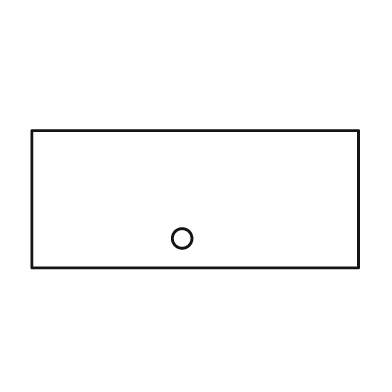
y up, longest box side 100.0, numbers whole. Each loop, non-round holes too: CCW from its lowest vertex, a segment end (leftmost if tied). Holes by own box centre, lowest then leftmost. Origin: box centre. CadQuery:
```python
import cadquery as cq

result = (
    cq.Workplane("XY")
    .moveTo(-50.0, -21.0)
    .lineTo(50.0, -21.0)
    .lineTo(50.0, 21.0)
    .lineTo(-50.0, 21.0)
    .close()
    .moveTo(-4.0, -12.0)
    .circle(3.0)
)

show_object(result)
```